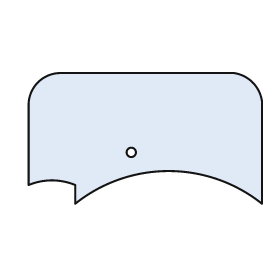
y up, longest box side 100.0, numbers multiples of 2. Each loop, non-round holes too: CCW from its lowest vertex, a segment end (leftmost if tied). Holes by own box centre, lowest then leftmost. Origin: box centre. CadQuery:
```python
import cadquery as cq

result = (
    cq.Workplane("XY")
    .moveTo(-30.0, -28.0)
    .threePointArc((10.0, -14.0), (50.0, -28.0))
    .lineTo(50.0, 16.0)
    .threePointArc((46.0, 24.0), (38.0, 28.0))
    .lineTo(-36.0, 28.0)
    .threePointArc((-46.0, 24.0), (-50.0, 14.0))
    .lineTo(-50.0, -20.0)
    .threePointArc((-40.0, -18.0), (-30.0, -20.0))
    .close()
    .moveTo(-6.0, -6.0)
    .circle(2.0)
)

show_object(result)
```